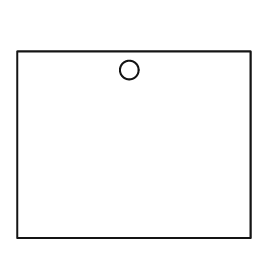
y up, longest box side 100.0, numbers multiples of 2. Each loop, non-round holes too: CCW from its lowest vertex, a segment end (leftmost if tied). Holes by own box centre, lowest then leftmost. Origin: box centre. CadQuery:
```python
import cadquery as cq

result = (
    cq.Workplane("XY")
    .moveTo(-50.0, -40.0)
    .lineTo(50.0, -40.0)
    .lineTo(50.0, 40.0)
    .lineTo(-50.0, 40.0)
    .close()
    .moveTo(-2.0, 32.0)
    .circle(4.0)
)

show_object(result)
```